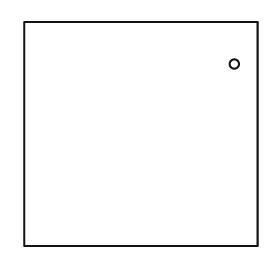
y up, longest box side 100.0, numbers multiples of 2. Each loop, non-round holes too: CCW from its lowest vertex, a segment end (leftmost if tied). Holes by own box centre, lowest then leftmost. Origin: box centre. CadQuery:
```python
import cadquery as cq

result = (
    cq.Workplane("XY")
    .moveTo(-50.0, -48.0)
    .lineTo(50.0, -48.0)
    .lineTo(50.0, 48.0)
    .lineTo(-50.0, 48.0)
    .close()
    .moveTo(40.0, 30.0)
    .circle(2.0)
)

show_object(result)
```